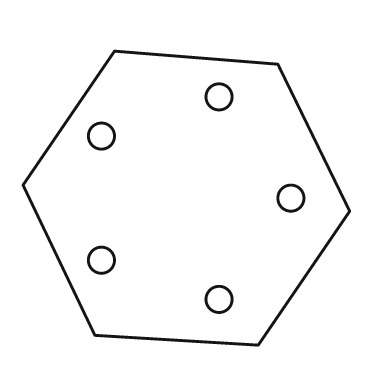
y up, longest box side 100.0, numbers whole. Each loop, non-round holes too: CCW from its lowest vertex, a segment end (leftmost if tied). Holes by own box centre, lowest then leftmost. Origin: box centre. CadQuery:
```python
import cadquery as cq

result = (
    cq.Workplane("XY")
    .moveTo(22.0, -45.0)
    .lineTo(50.0, -4.0)
    .lineTo(28.0, 41.0)
    .lineTo(-22.0, 45.0)
    .lineTo(-50.0, 4.0)
    .lineTo(-28.0, -42.0)
    .close()
    .moveTo(10.0, -31.0)
    .circle(4.0)
    .moveTo(-26.0, -19.0)
    .circle(4.0)
    .moveTo(32.0, 0.0)
    .circle(4.0)
    .moveTo(-26.0, 19.0)
    .circle(4.0)
    .moveTo(10.0, 31.0)
    .circle(4.0)
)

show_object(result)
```